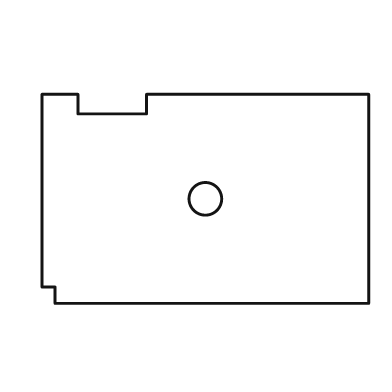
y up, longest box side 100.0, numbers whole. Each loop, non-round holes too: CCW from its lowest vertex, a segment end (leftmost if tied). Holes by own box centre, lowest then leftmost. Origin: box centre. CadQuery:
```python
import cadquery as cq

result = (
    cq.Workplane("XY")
    .moveTo(-46.0, -32.0)
    .lineTo(50.0, -32.0)
    .lineTo(50.0, 32.0)
    .lineTo(-18.0, 32.0)
    .lineTo(-18.0, 26.0)
    .lineTo(-39.0, 26.0)
    .lineTo(-39.0, 32.0)
    .lineTo(-50.0, 32.0)
    .lineTo(-50.0, -27.0)
    .lineTo(-46.0, -27.0)
    .close()
    .moveTo(0.0, 0.0)
    .circle(5.0)
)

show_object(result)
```